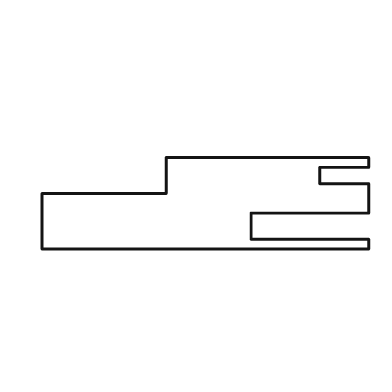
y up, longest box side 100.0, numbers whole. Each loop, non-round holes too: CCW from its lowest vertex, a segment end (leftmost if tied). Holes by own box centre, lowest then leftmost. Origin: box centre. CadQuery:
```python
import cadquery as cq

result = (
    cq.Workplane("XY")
    .moveTo(-50.0, -14.0)
    .lineTo(50.0, -14.0)
    .lineTo(50.0, -11.0)
    .lineTo(14.0, -11.0)
    .lineTo(14.0, -3.0)
    .lineTo(50.0, -3.0)
    .lineTo(50.0, 6.0)
    .lineTo(35.0, 6.0)
    .lineTo(35.0, 11.0)
    .lineTo(50.0, 11.0)
    .lineTo(50.0, 14.0)
    .lineTo(-12.0, 14.0)
    .lineTo(-12.0, 3.0)
    .lineTo(-50.0, 3.0)
    .close()
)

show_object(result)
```